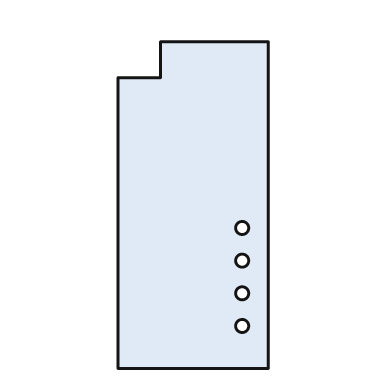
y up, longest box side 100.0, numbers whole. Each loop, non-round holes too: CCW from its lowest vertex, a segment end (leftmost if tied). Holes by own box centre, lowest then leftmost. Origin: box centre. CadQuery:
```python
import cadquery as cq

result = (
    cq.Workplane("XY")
    .moveTo(-23.0, -50.0)
    .lineTo(23.0, -50.0)
    .lineTo(23.0, 50.0)
    .lineTo(-10.0, 50.0)
    .lineTo(-10.0, 39.0)
    .lineTo(-23.0, 39.0)
    .close()
    .moveTo(15.0, -37.0)
    .circle(2.0)
    .moveTo(15.0, -27.0)
    .circle(2.0)
    .moveTo(15.0, -17.0)
    .circle(2.0)
    .moveTo(15.0, -7.0)
    .circle(2.0)
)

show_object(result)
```